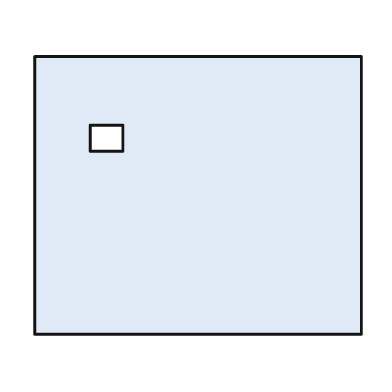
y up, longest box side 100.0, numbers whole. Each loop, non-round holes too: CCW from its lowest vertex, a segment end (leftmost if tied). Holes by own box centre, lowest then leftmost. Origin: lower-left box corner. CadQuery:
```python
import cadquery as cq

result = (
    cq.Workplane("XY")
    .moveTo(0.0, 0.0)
    .lineTo(100.0, 0.0)
    .lineTo(100.0, 85.0)
    .lineTo(0.0, 85.0)
    .close()
    .moveTo(17.0, 56.0)
    .lineTo(27.0, 56.0)
    .lineTo(27.0, 64.0)
    .lineTo(17.0, 64.0)
    .close()
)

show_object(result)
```